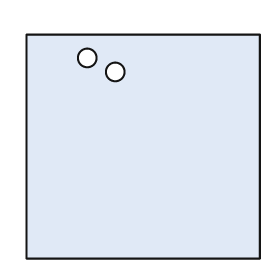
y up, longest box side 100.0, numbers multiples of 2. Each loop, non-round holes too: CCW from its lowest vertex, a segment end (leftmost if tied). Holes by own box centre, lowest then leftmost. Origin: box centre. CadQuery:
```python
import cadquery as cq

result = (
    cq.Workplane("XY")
    .moveTo(-50.0, -48.0)
    .lineTo(50.0, -48.0)
    .lineTo(50.0, 48.0)
    .lineTo(-50.0, 48.0)
    .close()
    .moveTo(-12.0, 32.0)
    .circle(4.0)
    .moveTo(-24.0, 38.0)
    .circle(4.0)
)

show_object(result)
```